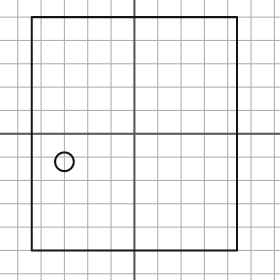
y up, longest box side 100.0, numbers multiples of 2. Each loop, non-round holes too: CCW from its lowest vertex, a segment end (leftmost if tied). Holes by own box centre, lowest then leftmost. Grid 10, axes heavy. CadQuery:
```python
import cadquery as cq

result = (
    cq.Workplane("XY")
    .moveTo(-44.0, -50.0)
    .lineTo(44.0, -50.0)
    .lineTo(44.0, 50.0)
    .lineTo(-44.0, 50.0)
    .close()
    .moveTo(-30.0, -12.0)
    .circle(4.0)
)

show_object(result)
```